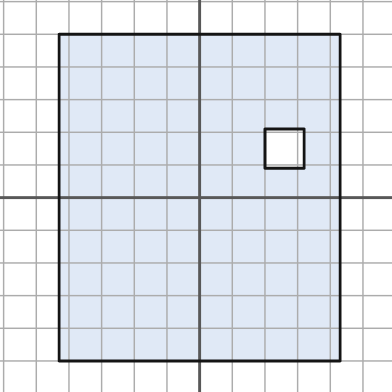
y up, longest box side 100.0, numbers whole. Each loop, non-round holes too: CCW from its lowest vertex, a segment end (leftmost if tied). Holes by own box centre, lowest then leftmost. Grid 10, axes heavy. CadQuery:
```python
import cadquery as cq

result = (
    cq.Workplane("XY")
    .moveTo(-43.0, -50.0)
    .lineTo(43.0, -50.0)
    .lineTo(43.0, 50.0)
    .lineTo(-43.0, 50.0)
    .close()
    .moveTo(20.0, 9.0)
    .lineTo(32.0, 9.0)
    .lineTo(32.0, 21.0)
    .lineTo(20.0, 21.0)
    .close()
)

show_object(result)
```